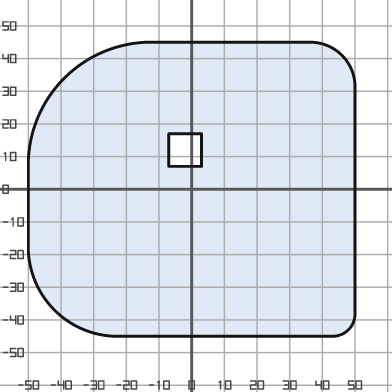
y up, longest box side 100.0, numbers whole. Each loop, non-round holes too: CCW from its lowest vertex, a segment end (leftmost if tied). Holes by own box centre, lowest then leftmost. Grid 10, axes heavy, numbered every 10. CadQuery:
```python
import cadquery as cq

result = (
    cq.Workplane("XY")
    .moveTo(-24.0, -45.0)
    .lineTo(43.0, -45.0)
    .threePointArc((48.0, -43.0), (50.0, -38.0))
    .lineTo(50.0, 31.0)
    .threePointArc((46.0, 41.0), (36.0, 45.0))
    .lineTo(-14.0, 45.0)
    .threePointArc((-39.0, 34.0), (-50.0, 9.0))
    .lineTo(-50.0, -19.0)
    .threePointArc((-42.0, -37.0), (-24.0, -45.0))
    .close()
    .moveTo(-7.0, 7.0)
    .lineTo(3.0, 7.0)
    .lineTo(3.0, 17.0)
    .lineTo(-7.0, 17.0)
    .close()
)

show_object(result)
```